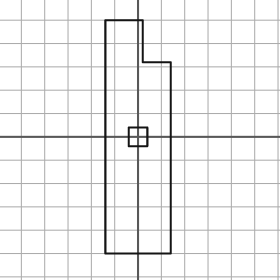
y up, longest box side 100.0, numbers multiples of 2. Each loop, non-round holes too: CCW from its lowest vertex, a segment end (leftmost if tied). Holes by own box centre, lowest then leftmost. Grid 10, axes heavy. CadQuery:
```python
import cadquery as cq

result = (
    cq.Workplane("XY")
    .moveTo(-14.0, -50.0)
    .lineTo(14.0, -50.0)
    .lineTo(14.0, 32.0)
    .lineTo(2.0, 32.0)
    .lineTo(2.0, 50.0)
    .lineTo(-14.0, 50.0)
    .close()
    .moveTo(-4.0, -4.0)
    .lineTo(4.0, -4.0)
    .lineTo(4.0, 4.0)
    .lineTo(-4.0, 4.0)
    .close()
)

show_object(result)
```